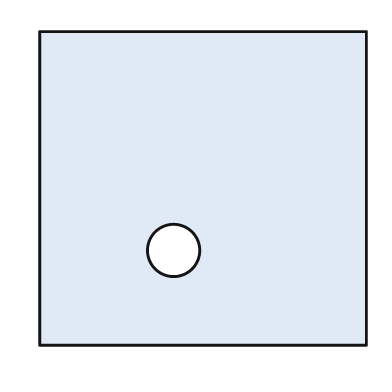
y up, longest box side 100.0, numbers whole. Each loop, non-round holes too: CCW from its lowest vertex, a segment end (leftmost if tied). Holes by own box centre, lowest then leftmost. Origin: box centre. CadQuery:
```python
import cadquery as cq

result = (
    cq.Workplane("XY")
    .moveTo(-50.0, -48.0)
    .lineTo(50.0, -48.0)
    .lineTo(50.0, 48.0)
    .lineTo(-50.0, 48.0)
    .close()
    .moveTo(-9.0, -19.0)
    .circle(8.0)
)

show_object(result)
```